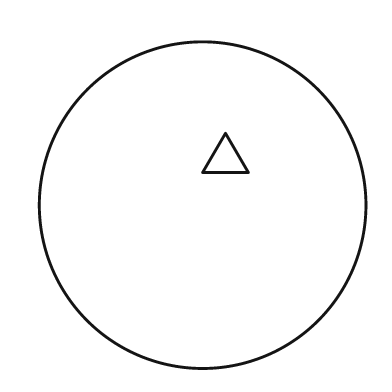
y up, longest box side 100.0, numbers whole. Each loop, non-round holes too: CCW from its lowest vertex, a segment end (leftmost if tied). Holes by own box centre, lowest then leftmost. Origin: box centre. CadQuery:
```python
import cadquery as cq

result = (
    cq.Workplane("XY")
    .moveTo(0.0, 0.0)
    .circle(50.0)
    .moveTo(0.0, 10.0)
    .lineTo(14.0, 10.0)
    .lineTo(7.0, 22.0)
    .close()
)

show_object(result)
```